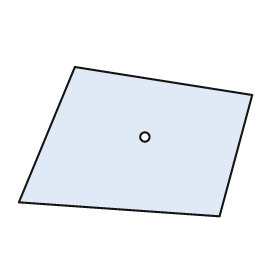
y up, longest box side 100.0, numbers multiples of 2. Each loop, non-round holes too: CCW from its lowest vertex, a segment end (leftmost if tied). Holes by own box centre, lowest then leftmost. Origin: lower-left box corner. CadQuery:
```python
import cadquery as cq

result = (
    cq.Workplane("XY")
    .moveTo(86.0, 0.0)
    .lineTo(100.0, 52.0)
    .lineTo(24.0, 64.0)
    .lineTo(0.0, 6.0)
    .close()
    .moveTo(54.0, 34.0)
    .circle(2.0)
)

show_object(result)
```